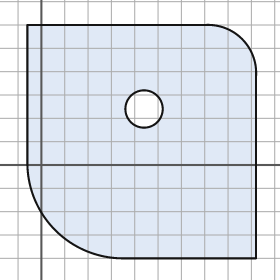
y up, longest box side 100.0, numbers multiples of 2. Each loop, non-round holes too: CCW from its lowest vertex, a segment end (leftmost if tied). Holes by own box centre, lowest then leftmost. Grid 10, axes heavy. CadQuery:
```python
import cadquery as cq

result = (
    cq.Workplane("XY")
    .moveTo(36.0, -40.0)
    .lineTo(92.0, -40.0)
    .lineTo(92.0, 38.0)
    .threePointArc((86.0, 54.0), (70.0, 60.0))
    .lineTo(-6.0, 60.0)
    .lineTo(-6.0, 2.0)
    .threePointArc((6.0, -28.0), (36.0, -40.0))
    .close()
    .moveTo(44.0, 24.0)
    .circle(8.0)
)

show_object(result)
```